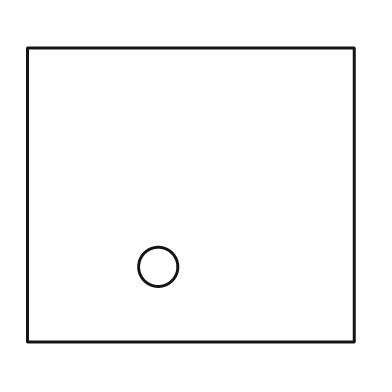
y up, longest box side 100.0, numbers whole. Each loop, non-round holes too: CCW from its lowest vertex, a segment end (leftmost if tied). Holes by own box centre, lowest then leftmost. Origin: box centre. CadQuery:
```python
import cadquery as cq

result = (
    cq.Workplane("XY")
    .moveTo(-50.0, -45.0)
    .lineTo(50.0, -45.0)
    .lineTo(50.0, 45.0)
    .lineTo(-50.0, 45.0)
    .close()
    .moveTo(-10.0, -22.0)
    .circle(6.0)
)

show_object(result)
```